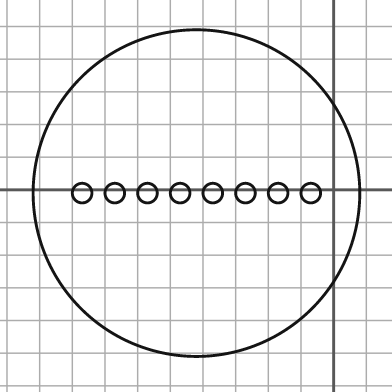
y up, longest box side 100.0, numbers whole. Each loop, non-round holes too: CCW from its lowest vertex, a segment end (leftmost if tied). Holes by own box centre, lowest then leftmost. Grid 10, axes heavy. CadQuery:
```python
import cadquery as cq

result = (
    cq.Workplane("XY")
    .moveTo(-42.0, -1.0)
    .circle(50.0)
    .moveTo(-77.0, -1.0)
    .circle(3.0)
    .moveTo(-67.0, -1.0)
    .circle(3.0)
    .moveTo(-57.0, -1.0)
    .circle(3.0)
    .moveTo(-47.0, -1.0)
    .circle(3.0)
    .moveTo(-37.0, -1.0)
    .circle(3.0)
    .moveTo(-27.0, -1.0)
    .circle(3.0)
    .moveTo(-17.0, -1.0)
    .circle(3.0)
    .moveTo(-7.0, -1.0)
    .circle(3.0)
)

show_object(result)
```